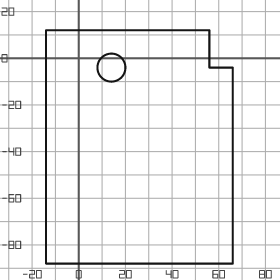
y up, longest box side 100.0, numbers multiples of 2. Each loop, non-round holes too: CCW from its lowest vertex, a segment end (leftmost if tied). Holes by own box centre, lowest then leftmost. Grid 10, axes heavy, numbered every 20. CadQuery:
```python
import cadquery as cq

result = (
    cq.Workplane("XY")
    .moveTo(-14.0, -88.0)
    .lineTo(66.0, -88.0)
    .lineTo(66.0, -4.0)
    .lineTo(56.0, -4.0)
    .lineTo(56.0, 12.0)
    .lineTo(-14.0, 12.0)
    .close()
    .moveTo(14.0, -4.0)
    .circle(6.0)
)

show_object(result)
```